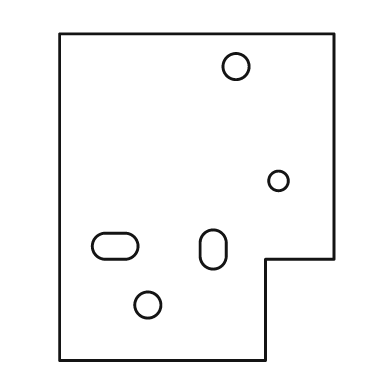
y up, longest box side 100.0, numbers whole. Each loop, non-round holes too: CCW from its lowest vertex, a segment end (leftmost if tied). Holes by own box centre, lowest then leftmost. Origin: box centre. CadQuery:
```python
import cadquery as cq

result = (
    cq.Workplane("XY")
    .moveTo(-42.0, -50.0)
    .lineTo(21.0, -50.0)
    .lineTo(21.0, -19.0)
    .lineTo(42.0, -19.0)
    .lineTo(42.0, 50.0)
    .lineTo(-42.0, 50.0)
    .close()
    .moveTo(-15.0, -33.0)
    .circle(4.0)
    .moveTo(1.0, -18.0)
    .threePointArc((5.0, -22.0), (9.0, -18.0))
    .lineTo(9.0, -14.0)
    .threePointArc((5.0, -10.0), (1.0, -14.0))
    .close()
    .moveTo(-28.0, -19.0)
    .lineTo(-22.0, -19.0)
    .threePointArc((-18.0, -15.0), (-22.0, -11.0))
    .lineTo(-28.0, -11.0)
    .threePointArc((-32.0, -15.0), (-28.0, -19.0))
    .close()
    .moveTo(25.0, 5.0)
    .circle(3.0)
    .moveTo(12.0, 40.0)
    .circle(4.0)
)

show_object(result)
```